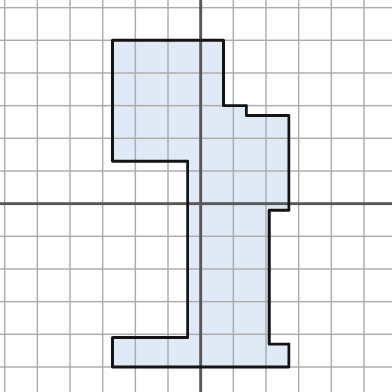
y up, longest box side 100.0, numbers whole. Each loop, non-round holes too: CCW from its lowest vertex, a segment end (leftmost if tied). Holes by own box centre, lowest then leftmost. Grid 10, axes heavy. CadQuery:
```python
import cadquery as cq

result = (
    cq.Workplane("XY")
    .moveTo(-27.0, -50.0)
    .lineTo(27.0, -50.0)
    .lineTo(27.0, -43.0)
    .lineTo(21.0, -43.0)
    .lineTo(21.0, -2.0)
    .lineTo(27.0, -2.0)
    .lineTo(27.0, 27.0)
    .lineTo(14.0, 27.0)
    .lineTo(14.0, 30.0)
    .lineTo(7.0, 30.0)
    .lineTo(7.0, 50.0)
    .lineTo(-27.0, 50.0)
    .lineTo(-27.0, 13.0)
    .lineTo(-4.0, 13.0)
    .lineTo(-4.0, -41.0)
    .lineTo(-27.0, -41.0)
    .close()
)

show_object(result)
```